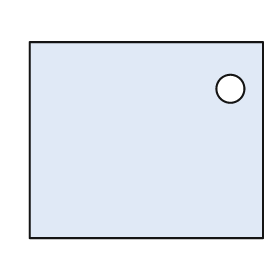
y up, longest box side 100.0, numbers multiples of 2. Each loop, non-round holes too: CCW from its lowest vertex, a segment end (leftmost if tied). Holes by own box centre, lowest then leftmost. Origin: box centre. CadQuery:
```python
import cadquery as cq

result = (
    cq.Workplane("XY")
    .moveTo(-50.0, -42.0)
    .lineTo(50.0, -42.0)
    .lineTo(50.0, 42.0)
    .lineTo(-50.0, 42.0)
    .close()
    .moveTo(36.0, 22.0)
    .circle(6.0)
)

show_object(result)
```